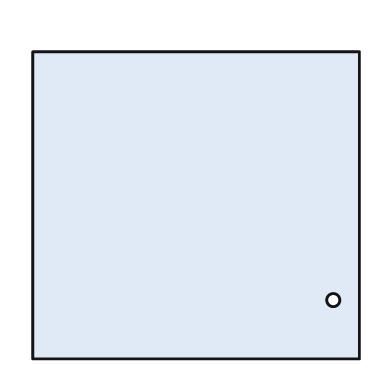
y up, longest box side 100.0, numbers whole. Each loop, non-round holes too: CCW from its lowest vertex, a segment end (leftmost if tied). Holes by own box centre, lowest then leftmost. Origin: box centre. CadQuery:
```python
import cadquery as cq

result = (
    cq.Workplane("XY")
    .moveTo(-50.0, -47.0)
    .lineTo(50.0, -47.0)
    .lineTo(50.0, 47.0)
    .lineTo(-50.0, 47.0)
    .close()
    .moveTo(42.0, -29.0)
    .circle(2.0)
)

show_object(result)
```